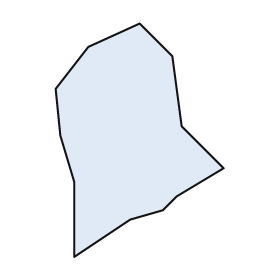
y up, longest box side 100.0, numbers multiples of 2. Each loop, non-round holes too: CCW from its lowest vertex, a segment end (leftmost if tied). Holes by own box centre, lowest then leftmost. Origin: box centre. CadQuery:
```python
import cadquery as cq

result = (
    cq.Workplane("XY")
    .moveTo(-28.0, -50.0)
    .lineTo(-4.0, -34.0)
    .lineTo(10.0, -30.0)
    .lineTo(16.0, -24.0)
    .lineTo(36.0, -12.0)
    .lineTo(18.0, 6.0)
    .lineTo(14.0, 36.0)
    .lineTo(0.0, 50.0)
    .lineTo(-22.0, 40.0)
    .lineTo(-36.0, 22.0)
    .lineTo(-34.0, 2.0)
    .lineTo(-28.0, -18.0)
    .close()
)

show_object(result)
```